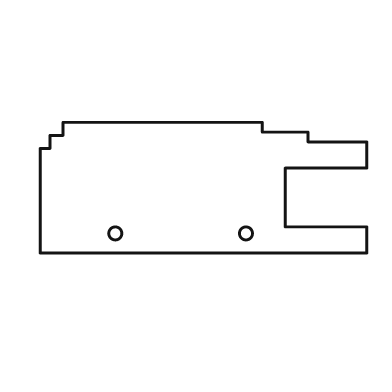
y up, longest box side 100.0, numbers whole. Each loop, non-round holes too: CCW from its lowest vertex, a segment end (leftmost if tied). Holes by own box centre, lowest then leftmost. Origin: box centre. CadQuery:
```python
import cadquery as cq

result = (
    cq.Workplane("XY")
    .moveTo(-50.0, -20.0)
    .lineTo(50.0, -20.0)
    .lineTo(50.0, -12.0)
    .lineTo(25.0, -12.0)
    .lineTo(25.0, 6.0)
    .lineTo(50.0, 6.0)
    .lineTo(50.0, 14.0)
    .lineTo(32.0, 14.0)
    .lineTo(32.0, 17.0)
    .lineTo(18.0, 17.0)
    .lineTo(18.0, 20.0)
    .lineTo(-43.0, 20.0)
    .lineTo(-43.0, 16.0)
    .lineTo(-47.0, 16.0)
    .lineTo(-47.0, 12.0)
    .lineTo(-50.0, 12.0)
    .close()
    .moveTo(-27.0, -14.0)
    .circle(2.0)
    .moveTo(13.0, -14.0)
    .circle(2.0)
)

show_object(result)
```